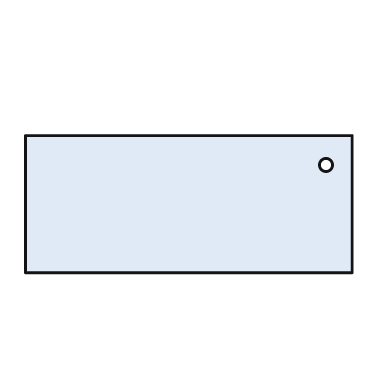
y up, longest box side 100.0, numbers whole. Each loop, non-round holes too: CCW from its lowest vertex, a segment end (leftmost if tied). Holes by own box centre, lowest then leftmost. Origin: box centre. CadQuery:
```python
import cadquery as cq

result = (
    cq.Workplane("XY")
    .moveTo(-50.0, -21.0)
    .lineTo(50.0, -21.0)
    .lineTo(50.0, 21.0)
    .lineTo(-50.0, 21.0)
    .close()
    .moveTo(42.0, 12.0)
    .circle(2.0)
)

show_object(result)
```